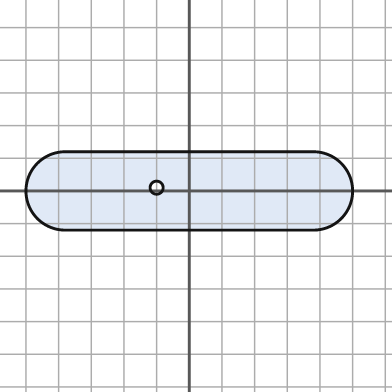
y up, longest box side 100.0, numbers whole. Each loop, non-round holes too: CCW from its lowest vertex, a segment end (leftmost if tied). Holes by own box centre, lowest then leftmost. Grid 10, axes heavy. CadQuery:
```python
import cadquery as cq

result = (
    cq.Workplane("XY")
    .moveTo(-38.0, -12.0)
    .lineTo(38.0, -12.0)
    .threePointArc((50.0, 0.0), (38.0, 12.0))
    .lineTo(-38.0, 12.0)
    .threePointArc((-50.0, 0.0), (-38.0, -12.0))
    .close()
    .moveTo(-10.0, 1.0)
    .circle(2.0)
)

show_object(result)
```